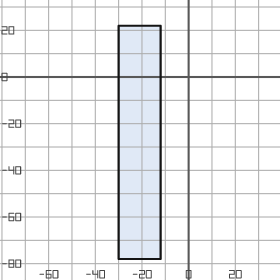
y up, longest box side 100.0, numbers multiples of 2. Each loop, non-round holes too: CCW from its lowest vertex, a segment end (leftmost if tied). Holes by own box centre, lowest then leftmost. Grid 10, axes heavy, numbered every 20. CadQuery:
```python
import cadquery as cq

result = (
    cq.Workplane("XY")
    .moveTo(-30.0, -78.0)
    .lineTo(-12.0, -78.0)
    .lineTo(-12.0, 22.0)
    .lineTo(-30.0, 22.0)
    .close()
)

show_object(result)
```